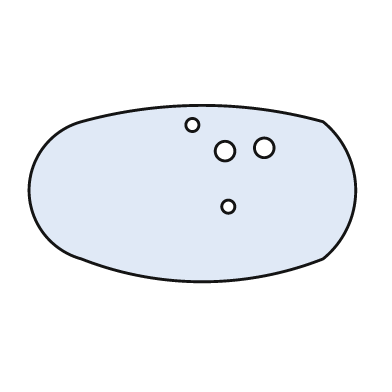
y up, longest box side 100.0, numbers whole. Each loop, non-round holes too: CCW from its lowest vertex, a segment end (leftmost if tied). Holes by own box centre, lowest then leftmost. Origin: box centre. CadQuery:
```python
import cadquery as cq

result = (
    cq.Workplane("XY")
    .moveTo(-34.0, -20.0)
    .threePointArc((3.0, -27.0), (40.0, -20.0))
    .threePointArc((50.0, 1.0), (40.0, 22.0))
    .threePointArc((3.0, 27.0), (-34.0, 22.0))
    .threePointArc((-50.0, 1.0), (-34.0, -20.0))
    .close()
    .moveTo(11.0, -4.0)
    .circle(2.0)
    .moveTo(10.0, 13.0)
    .circle(3.0)
    .moveTo(22.0, 14.0)
    .circle(3.0)
    .moveTo(0.0, 21.0)
    .circle(2.0)
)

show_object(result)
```